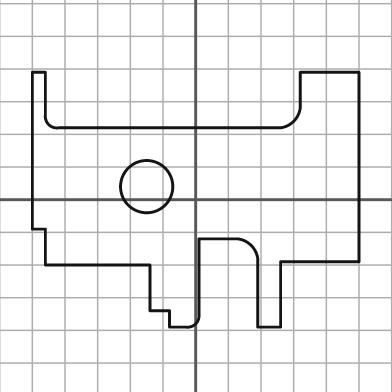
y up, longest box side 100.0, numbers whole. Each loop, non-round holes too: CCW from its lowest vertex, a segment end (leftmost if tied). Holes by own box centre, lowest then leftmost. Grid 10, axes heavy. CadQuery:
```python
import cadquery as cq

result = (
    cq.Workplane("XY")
    .moveTo(-8.0, -39.0)
    .lineTo(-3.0, -39.0)
    .threePointArc((0.0, -38.0), (1.0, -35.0))
    .lineTo(1.0, -12.0)
    .lineTo(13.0, -12.0)
    .threePointArc((17.0, -14.0), (19.0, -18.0))
    .lineTo(19.0, -39.0)
    .lineTo(26.0, -39.0)
    .lineTo(26.0, -19.0)
    .lineTo(50.0, -19.0)
    .lineTo(50.0, 39.0)
    .lineTo(32.0, 39.0)
    .lineTo(32.0, 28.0)
    .threePointArc((30.0, 24.0), (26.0, 22.0))
    .lineTo(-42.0, 22.0)
    .threePointArc((-45.0, 23.0), (-46.0, 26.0))
    .lineTo(-46.0, 39.0)
    .lineTo(-50.0, 39.0)
    .lineTo(-50.0, -9.0)
    .lineTo(-46.0, -9.0)
    .lineTo(-46.0, -20.0)
    .lineTo(-14.0, -20.0)
    .lineTo(-14.0, -34.0)
    .lineTo(-8.0, -34.0)
    .close()
    .moveTo(-15.0, 4.0)
    .circle(8.0)
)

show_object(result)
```